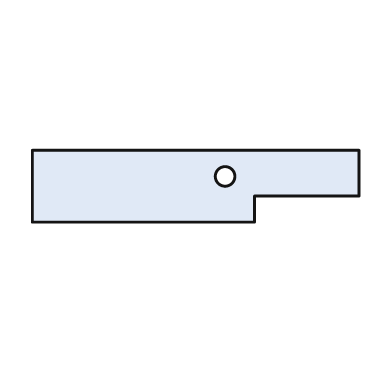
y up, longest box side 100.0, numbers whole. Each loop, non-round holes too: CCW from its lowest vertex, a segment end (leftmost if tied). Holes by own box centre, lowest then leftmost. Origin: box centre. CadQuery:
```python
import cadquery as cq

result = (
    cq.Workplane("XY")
    .moveTo(-50.0, -11.0)
    .lineTo(18.0, -11.0)
    .lineTo(18.0, -3.0)
    .lineTo(50.0, -3.0)
    .lineTo(50.0, 11.0)
    .lineTo(-50.0, 11.0)
    .close()
    .moveTo(9.0, 3.0)
    .circle(3.0)
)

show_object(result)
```